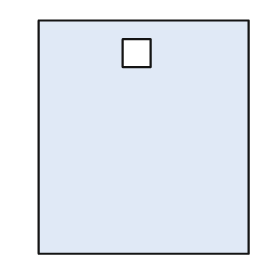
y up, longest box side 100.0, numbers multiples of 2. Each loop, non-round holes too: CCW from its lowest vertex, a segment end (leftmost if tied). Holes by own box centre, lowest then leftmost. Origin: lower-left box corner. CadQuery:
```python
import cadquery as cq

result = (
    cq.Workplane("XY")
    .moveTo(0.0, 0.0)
    .lineTo(90.0, 0.0)
    .lineTo(90.0, 100.0)
    .lineTo(0.0, 100.0)
    .close()
    .moveTo(36.0, 80.0)
    .lineTo(48.0, 80.0)
    .lineTo(48.0, 92.0)
    .lineTo(36.0, 92.0)
    .close()
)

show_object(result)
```